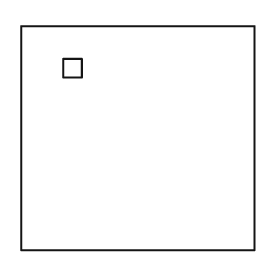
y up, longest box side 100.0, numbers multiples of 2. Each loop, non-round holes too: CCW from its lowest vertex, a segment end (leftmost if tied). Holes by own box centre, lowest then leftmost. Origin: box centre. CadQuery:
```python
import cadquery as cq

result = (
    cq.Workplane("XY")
    .moveTo(-50.0, -48.0)
    .lineTo(50.0, -48.0)
    .lineTo(50.0, 48.0)
    .lineTo(-50.0, 48.0)
    .close()
    .moveTo(-32.0, 26.0)
    .lineTo(-24.0, 26.0)
    .lineTo(-24.0, 34.0)
    .lineTo(-32.0, 34.0)
    .close()
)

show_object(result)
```